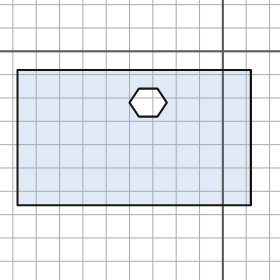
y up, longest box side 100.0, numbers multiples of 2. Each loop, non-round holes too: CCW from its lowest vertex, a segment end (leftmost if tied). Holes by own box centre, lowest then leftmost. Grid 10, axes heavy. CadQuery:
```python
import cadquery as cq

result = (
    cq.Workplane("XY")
    .moveTo(-88.0, -66.0)
    .lineTo(12.0, -66.0)
    .lineTo(12.0, -8.0)
    .lineTo(-88.0, -8.0)
    .close()
    .moveTo(-36.0, -28.0)
    .lineTo(-28.0, -28.0)
    .lineTo(-24.0, -22.0)
    .lineTo(-28.0, -16.0)
    .lineTo(-36.0, -16.0)
    .lineTo(-40.0, -22.0)
    .close()
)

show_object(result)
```